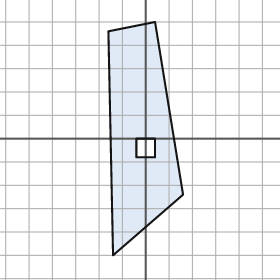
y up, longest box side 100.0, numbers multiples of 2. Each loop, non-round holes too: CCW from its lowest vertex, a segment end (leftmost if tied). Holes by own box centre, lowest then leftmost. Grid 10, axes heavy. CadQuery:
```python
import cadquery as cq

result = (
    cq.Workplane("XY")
    .moveTo(-14.0, -50.0)
    .lineTo(16.0, -24.0)
    .lineTo(4.0, 50.0)
    .lineTo(-16.0, 46.0)
    .close()
    .moveTo(-4.0, -8.0)
    .lineTo(4.0, -8.0)
    .lineTo(4.0, 0.0)
    .lineTo(-4.0, 0.0)
    .close()
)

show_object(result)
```